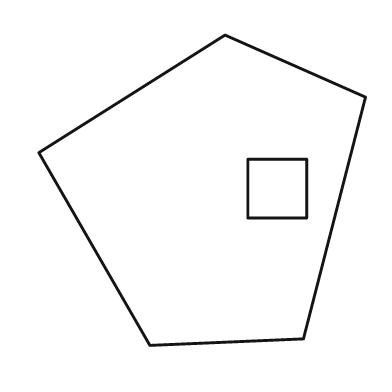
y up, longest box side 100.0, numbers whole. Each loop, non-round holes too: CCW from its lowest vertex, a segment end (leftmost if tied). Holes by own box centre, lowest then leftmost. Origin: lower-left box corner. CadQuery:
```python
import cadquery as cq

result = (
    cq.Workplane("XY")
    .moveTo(34.0, 0.0)
    .lineTo(81.0, 2.0)
    .lineTo(100.0, 76.0)
    .lineTo(57.0, 95.0)
    .lineTo(0.0, 59.0)
    .close()
    .moveTo(64.0, 39.0)
    .lineTo(82.0, 39.0)
    .lineTo(82.0, 57.0)
    .lineTo(64.0, 57.0)
    .close()
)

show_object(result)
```